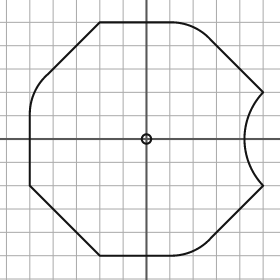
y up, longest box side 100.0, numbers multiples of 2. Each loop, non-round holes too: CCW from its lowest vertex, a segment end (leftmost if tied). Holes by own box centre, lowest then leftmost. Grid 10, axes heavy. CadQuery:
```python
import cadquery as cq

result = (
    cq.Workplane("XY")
    .moveTo(-20.0, -50.0)
    .lineTo(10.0, -50.0)
    .threePointArc((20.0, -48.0), (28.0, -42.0))
    .lineTo(50.0, -20.0)
    .threePointArc((42.0, 0.0), (50.0, 20.0))
    .lineTo(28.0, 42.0)
    .threePointArc((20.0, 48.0), (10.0, 50.0))
    .lineTo(-20.0, 50.0)
    .lineTo(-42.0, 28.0)
    .threePointArc((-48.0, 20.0), (-50.0, 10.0))
    .lineTo(-50.0, -20.0)
    .close()
    .moveTo(0.0, 0.0)
    .circle(2.0)
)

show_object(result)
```